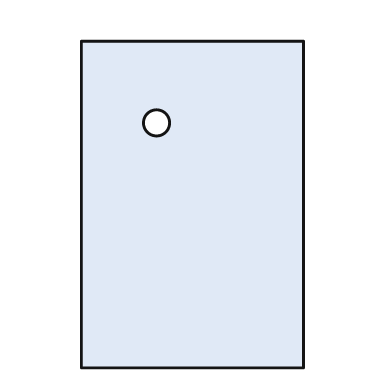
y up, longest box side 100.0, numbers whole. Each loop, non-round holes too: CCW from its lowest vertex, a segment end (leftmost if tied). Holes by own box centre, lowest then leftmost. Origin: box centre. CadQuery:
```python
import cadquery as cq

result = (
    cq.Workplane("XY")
    .moveTo(-34.0, -50.0)
    .lineTo(34.0, -50.0)
    .lineTo(34.0, 50.0)
    .lineTo(-34.0, 50.0)
    .close()
    .moveTo(-11.0, 25.0)
    .circle(4.0)
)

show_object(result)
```